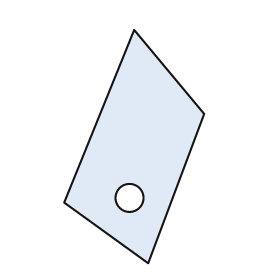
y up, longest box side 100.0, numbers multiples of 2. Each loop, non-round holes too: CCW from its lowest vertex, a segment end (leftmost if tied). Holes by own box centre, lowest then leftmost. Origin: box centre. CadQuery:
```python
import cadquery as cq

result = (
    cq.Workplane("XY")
    .moveTo(6.0, -50.0)
    .lineTo(30.0, 14.0)
    .lineTo(0.0, 50.0)
    .lineTo(-30.0, -24.0)
    .close()
    .moveTo(-2.0, -22.0)
    .circle(6.0)
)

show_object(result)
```